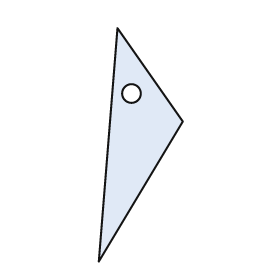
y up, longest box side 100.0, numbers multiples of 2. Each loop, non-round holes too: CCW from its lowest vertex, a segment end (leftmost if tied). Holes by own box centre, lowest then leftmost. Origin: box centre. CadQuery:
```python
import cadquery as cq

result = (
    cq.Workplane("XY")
    .moveTo(-18.0, -50.0)
    .lineTo(18.0, 10.0)
    .lineTo(-10.0, 50.0)
    .close()
    .moveTo(-4.0, 22.0)
    .circle(4.0)
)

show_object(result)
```